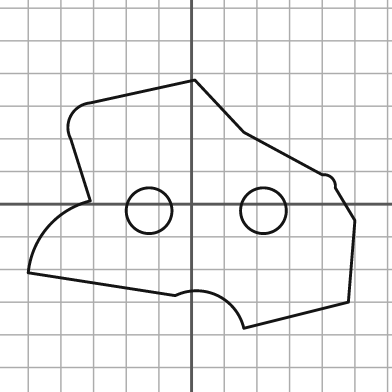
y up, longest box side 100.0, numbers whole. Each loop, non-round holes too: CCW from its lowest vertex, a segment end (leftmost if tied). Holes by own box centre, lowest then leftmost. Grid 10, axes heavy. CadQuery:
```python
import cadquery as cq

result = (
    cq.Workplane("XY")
    .moveTo(16.0, -38.0)
    .lineTo(48.0, -30.0)
    .lineTo(50.0, -5.0)
    .lineTo(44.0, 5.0)
    .threePointArc((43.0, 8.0), (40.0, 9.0))
    .lineTo(16.0, 22.0)
    .lineTo(1.0, 38.0)
    .lineTo(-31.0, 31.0)
    .threePointArc((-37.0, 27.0), (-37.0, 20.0))
    .lineTo(-31.0, 1.0)
    .threePointArc((-44.0, -7.0), (-50.0, -21.0))
    .lineTo(-5.0, -28.0)
    .threePointArc((8.0, -28.0), (16.0, -38.0))
    .close()
    .moveTo(-13.0, -2.0)
    .circle(7.0)
    .moveTo(22.0, -2.0)
    .circle(7.0)
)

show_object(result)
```